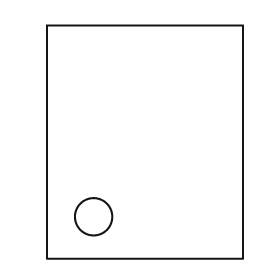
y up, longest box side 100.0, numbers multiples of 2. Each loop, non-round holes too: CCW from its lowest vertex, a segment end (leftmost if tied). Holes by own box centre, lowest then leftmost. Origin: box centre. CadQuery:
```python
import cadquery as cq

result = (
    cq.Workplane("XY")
    .moveTo(-42.0, -50.0)
    .lineTo(42.0, -50.0)
    .lineTo(42.0, 50.0)
    .lineTo(-42.0, 50.0)
    .close()
    .moveTo(-22.0, -32.0)
    .circle(8.0)
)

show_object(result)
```